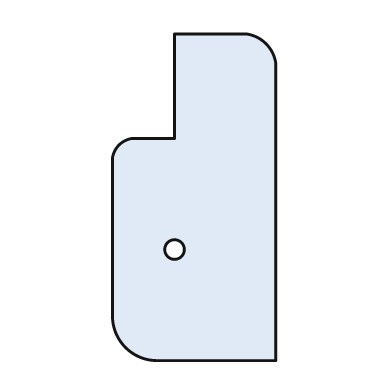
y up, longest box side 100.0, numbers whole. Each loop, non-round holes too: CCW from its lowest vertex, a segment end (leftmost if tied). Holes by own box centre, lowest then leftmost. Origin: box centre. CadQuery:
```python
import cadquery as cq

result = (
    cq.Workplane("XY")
    .moveTo(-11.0, -50.0)
    .lineTo(25.0, -50.0)
    .lineTo(25.0, 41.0)
    .threePointArc((22.0, 47.0), (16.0, 50.0))
    .lineTo(-6.0, 50.0)
    .lineTo(-6.0, 18.0)
    .lineTo(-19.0, 18.0)
    .threePointArc((-23.0, 16.0), (-25.0, 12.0))
    .lineTo(-25.0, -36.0)
    .threePointArc((-21.0, -46.0), (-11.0, -50.0))
    .close()
    .moveTo(-6.0, -16.0)
    .circle(3.0)
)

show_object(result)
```